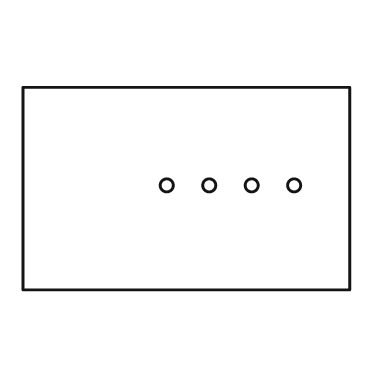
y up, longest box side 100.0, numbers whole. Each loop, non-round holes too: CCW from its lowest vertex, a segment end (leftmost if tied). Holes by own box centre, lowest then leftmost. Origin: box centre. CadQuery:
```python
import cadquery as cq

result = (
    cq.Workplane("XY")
    .moveTo(-50.0, -31.0)
    .lineTo(50.0, -31.0)
    .lineTo(50.0, 31.0)
    .lineTo(-50.0, 31.0)
    .close()
    .moveTo(-6.0, 1.0)
    .circle(2.0)
    .moveTo(7.0, 1.0)
    .circle(2.0)
    .moveTo(20.0, 1.0)
    .circle(2.0)
    .moveTo(33.0, 1.0)
    .circle(2.0)
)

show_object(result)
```